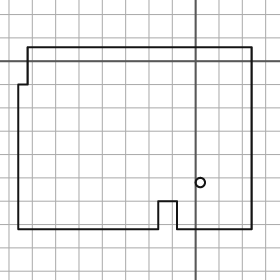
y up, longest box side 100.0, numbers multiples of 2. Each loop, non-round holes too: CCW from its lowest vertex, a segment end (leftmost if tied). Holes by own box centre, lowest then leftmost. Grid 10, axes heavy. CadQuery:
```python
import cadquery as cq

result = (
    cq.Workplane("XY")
    .moveTo(-76.0, -72.0)
    .lineTo(-16.0, -72.0)
    .lineTo(-16.0, -60.0)
    .lineTo(-8.0, -60.0)
    .lineTo(-8.0, -72.0)
    .lineTo(24.0, -72.0)
    .lineTo(24.0, 6.0)
    .lineTo(-72.0, 6.0)
    .lineTo(-72.0, -10.0)
    .lineTo(-76.0, -10.0)
    .close()
    .moveTo(2.0, -52.0)
    .circle(2.0)
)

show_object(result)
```